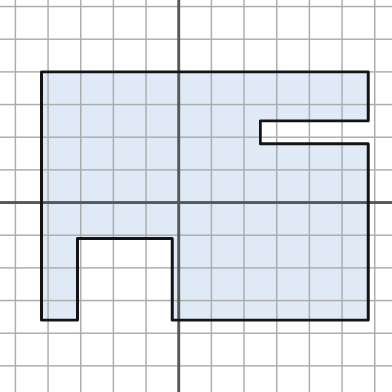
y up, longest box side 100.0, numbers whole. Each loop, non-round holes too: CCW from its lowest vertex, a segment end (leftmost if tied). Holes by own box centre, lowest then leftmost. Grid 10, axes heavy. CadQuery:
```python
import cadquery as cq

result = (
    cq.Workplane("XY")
    .moveTo(-42.0, -36.0)
    .lineTo(-31.0, -36.0)
    .lineTo(-31.0, -11.0)
    .lineTo(-2.0, -11.0)
    .lineTo(-2.0, -36.0)
    .lineTo(58.0, -36.0)
    .lineTo(58.0, 18.0)
    .lineTo(25.0, 18.0)
    .lineTo(25.0, 25.0)
    .lineTo(58.0, 25.0)
    .lineTo(58.0, 40.0)
    .lineTo(-42.0, 40.0)
    .close()
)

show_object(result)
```